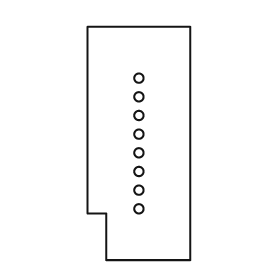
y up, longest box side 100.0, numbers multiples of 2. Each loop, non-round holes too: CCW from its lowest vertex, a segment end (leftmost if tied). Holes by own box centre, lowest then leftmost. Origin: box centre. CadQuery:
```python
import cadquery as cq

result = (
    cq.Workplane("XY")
    .moveTo(-14.0, -50.0)
    .lineTo(22.0, -50.0)
    .lineTo(22.0, 50.0)
    .lineTo(-22.0, 50.0)
    .lineTo(-22.0, -30.0)
    .lineTo(-14.0, -30.0)
    .close()
    .moveTo(0.0, -28.0)
    .circle(2.0)
    .moveTo(0.0, -20.0)
    .circle(2.0)
    .moveTo(0.0, -12.0)
    .circle(2.0)
    .moveTo(0.0, -4.0)
    .circle(2.0)
    .moveTo(0.0, 4.0)
    .circle(2.0)
    .moveTo(0.0, 12.0)
    .circle(2.0)
    .moveTo(0.0, 20.0)
    .circle(2.0)
    .moveTo(0.0, 28.0)
    .circle(2.0)
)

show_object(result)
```